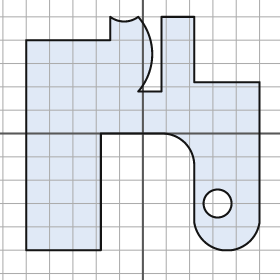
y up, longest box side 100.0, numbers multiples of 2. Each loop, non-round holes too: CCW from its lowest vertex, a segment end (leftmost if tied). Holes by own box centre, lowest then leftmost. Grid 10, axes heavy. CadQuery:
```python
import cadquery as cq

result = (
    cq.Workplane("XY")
    .moveTo(-50.0, -50.0)
    .lineTo(-18.0, -50.0)
    .lineTo(-18.0, 0.0)
    .lineTo(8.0, 0.0)
    .threePointArc((18.0, -4.0), (22.0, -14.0))
    .lineTo(22.0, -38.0)
    .threePointArc((26.0, -46.0), (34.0, -50.0))
    .lineTo(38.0, -50.0)
    .threePointArc((46.0, -46.0), (50.0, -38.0))
    .lineTo(50.0, 22.0)
    .lineTo(22.0, 22.0)
    .lineTo(22.0, 50.0)
    .lineTo(8.0, 50.0)
    .lineTo(8.0, 18.0)
    .lineTo(-2.0, 18.0)
    .threePointArc((4.0, 34.0), (-2.0, 50.0))
    .threePointArc((-8.0, 48.0), (-14.0, 50.0))
    .lineTo(-14.0, 40.0)
    .lineTo(-50.0, 40.0)
    .close()
    .moveTo(32.0, -30.0)
    .circle(6.0)
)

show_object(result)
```